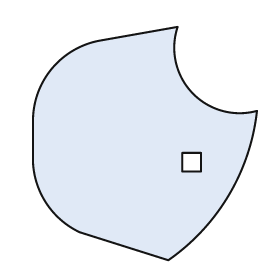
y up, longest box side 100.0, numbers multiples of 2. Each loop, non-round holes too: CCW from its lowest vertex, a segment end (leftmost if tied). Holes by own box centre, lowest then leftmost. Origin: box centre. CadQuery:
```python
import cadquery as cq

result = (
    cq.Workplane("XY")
    .moveTo(10.0, -50.0)
    .threePointArc((36.0, -22.0), (48.0, 14.0))
    .threePointArc((20.0, 22.0), (14.0, 50.0))
    .lineTo(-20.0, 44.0)
    .threePointArc((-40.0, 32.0), (-48.0, 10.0))
    .lineTo(-48.0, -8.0)
    .threePointArc((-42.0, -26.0), (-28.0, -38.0))
    .close()
    .moveTo(16.0, -12.0)
    .lineTo(24.0, -12.0)
    .lineTo(24.0, -4.0)
    .lineTo(16.0, -4.0)
    .close()
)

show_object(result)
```